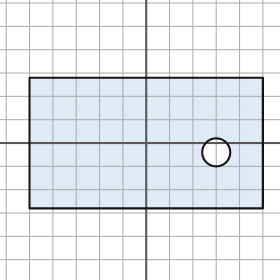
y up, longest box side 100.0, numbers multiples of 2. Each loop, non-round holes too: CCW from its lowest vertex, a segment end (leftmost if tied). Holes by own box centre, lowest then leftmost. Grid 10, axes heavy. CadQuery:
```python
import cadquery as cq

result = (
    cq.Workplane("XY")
    .moveTo(-50.0, -28.0)
    .lineTo(50.0, -28.0)
    .lineTo(50.0, 28.0)
    .lineTo(-50.0, 28.0)
    .close()
    .moveTo(30.0, -4.0)
    .circle(6.0)
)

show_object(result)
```